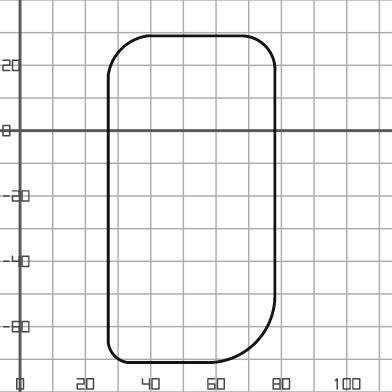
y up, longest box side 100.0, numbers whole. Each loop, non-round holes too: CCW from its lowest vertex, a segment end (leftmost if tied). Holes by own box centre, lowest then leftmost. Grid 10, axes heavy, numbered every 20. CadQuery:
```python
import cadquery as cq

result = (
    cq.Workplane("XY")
    .moveTo(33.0, -71.0)
    .lineTo(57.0, -71.0)
    .threePointArc((72.0, -65.0), (78.0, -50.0))
    .lineTo(78.0, 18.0)
    .threePointArc((75.0, 26.0), (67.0, 29.0))
    .lineTo(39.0, 29.0)
    .threePointArc((31.0, 25.0), (27.0, 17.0))
    .lineTo(27.0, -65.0)
    .threePointArc((29.0, -69.0), (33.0, -71.0))
    .close()
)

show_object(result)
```